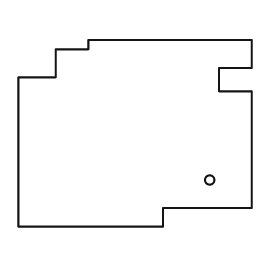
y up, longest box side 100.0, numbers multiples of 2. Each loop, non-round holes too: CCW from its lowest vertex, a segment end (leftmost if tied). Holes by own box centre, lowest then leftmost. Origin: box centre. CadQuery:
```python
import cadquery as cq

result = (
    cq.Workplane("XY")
    .moveTo(-50.0, -40.0)
    .lineTo(12.0, -40.0)
    .lineTo(12.0, -32.0)
    .lineTo(50.0, -32.0)
    .lineTo(50.0, 18.0)
    .lineTo(36.0, 18.0)
    .lineTo(36.0, 28.0)
    .lineTo(50.0, 28.0)
    .lineTo(50.0, 40.0)
    .lineTo(-20.0, 40.0)
    .lineTo(-20.0, 36.0)
    .lineTo(-34.0, 36.0)
    .lineTo(-34.0, 24.0)
    .lineTo(-50.0, 24.0)
    .close()
    .moveTo(32.0, -20.0)
    .circle(2.0)
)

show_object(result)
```